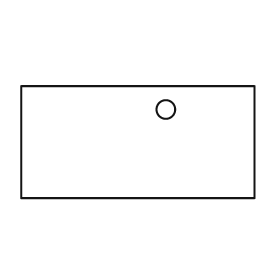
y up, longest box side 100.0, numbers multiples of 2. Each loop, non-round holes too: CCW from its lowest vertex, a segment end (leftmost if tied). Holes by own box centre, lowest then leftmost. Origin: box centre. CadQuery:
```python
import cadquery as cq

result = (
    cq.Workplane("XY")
    .moveTo(-50.0, -24.0)
    .lineTo(50.0, -24.0)
    .lineTo(50.0, 24.0)
    .lineTo(-50.0, 24.0)
    .close()
    .moveTo(12.0, 14.0)
    .circle(4.0)
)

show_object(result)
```